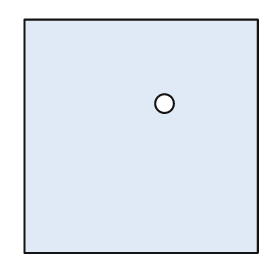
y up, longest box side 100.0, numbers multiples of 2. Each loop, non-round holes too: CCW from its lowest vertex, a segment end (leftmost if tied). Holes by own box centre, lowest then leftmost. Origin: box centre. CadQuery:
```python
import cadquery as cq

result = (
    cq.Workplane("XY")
    .moveTo(-50.0, -50.0)
    .lineTo(50.0, -50.0)
    .lineTo(50.0, 50.0)
    .lineTo(-50.0, 50.0)
    .close()
    .moveTo(10.0, 14.0)
    .circle(4.0)
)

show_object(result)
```